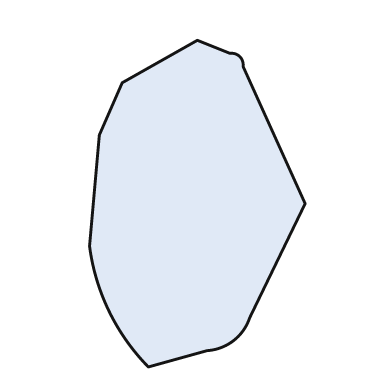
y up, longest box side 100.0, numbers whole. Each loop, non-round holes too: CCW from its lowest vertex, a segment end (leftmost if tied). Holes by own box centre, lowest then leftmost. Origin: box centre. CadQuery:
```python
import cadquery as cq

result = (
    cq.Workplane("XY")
    .moveTo(-15.0, -50.0)
    .lineTo(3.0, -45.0)
    .threePointArc((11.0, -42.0), (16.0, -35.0))
    .lineTo(33.0, 0.0)
    .lineTo(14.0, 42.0)
    .threePointArc((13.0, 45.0), (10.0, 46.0))
    .lineTo(0.0, 50.0)
    .lineTo(-23.0, 37.0)
    .lineTo(-30.0, 21.0)
    .lineTo(-33.0, -13.0)
    .threePointArc((-27.0, -33.0), (-15.0, -50.0))
    .close()
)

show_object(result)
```